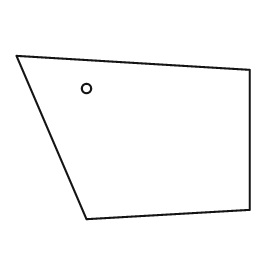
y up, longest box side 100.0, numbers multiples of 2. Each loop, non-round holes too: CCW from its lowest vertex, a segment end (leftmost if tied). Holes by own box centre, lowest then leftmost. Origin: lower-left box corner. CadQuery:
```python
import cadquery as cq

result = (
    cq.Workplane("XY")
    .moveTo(30.0, 0.0)
    .lineTo(100.0, 4.0)
    .lineTo(100.0, 64.0)
    .lineTo(0.0, 70.0)
    .close()
    .moveTo(30.0, 56.0)
    .circle(2.0)
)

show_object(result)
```